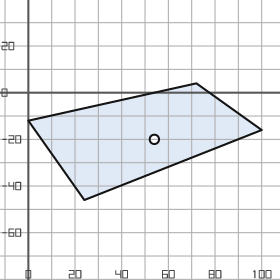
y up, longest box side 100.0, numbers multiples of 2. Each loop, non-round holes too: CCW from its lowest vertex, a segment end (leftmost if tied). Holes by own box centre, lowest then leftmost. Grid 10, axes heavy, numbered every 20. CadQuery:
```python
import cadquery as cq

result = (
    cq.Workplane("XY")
    .moveTo(24.0, -46.0)
    .lineTo(100.0, -16.0)
    .lineTo(72.0, 4.0)
    .lineTo(0.0, -12.0)
    .close()
    .moveTo(54.0, -20.0)
    .circle(2.0)
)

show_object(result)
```